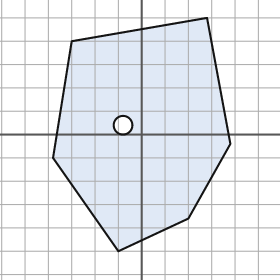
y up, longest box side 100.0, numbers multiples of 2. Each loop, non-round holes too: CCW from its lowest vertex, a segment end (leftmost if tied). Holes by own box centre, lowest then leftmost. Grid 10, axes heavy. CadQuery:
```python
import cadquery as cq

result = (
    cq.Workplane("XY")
    .moveTo(-10.0, -50.0)
    .lineTo(20.0, -36.0)
    .lineTo(38.0, -4.0)
    .lineTo(28.0, 50.0)
    .lineTo(-30.0, 40.0)
    .lineTo(-38.0, -10.0)
    .close()
    .moveTo(-8.0, 4.0)
    .circle(4.0)
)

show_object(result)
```